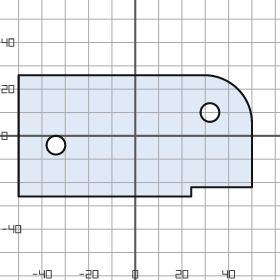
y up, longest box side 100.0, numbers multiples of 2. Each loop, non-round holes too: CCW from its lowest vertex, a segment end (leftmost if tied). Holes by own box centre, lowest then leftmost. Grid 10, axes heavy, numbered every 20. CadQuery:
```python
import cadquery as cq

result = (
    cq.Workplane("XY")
    .moveTo(-50.0, -26.0)
    .lineTo(24.0, -26.0)
    .lineTo(24.0, -22.0)
    .lineTo(50.0, -22.0)
    .lineTo(50.0, 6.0)
    .threePointArc((44.0, 20.0), (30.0, 26.0))
    .lineTo(-50.0, 26.0)
    .close()
    .moveTo(-34.0, -4.0)
    .circle(4.0)
    .moveTo(32.0, 10.0)
    .circle(4.0)
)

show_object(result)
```